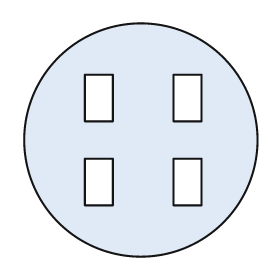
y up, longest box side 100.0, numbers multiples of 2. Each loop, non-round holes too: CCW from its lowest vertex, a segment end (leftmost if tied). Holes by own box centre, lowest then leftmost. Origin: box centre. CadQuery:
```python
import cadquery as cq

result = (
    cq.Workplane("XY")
    .moveTo(0.0, 0.0)
    .circle(50.0)
    .moveTo(-24.0, -28.0)
    .lineTo(-12.0, -28.0)
    .lineTo(-12.0, -8.0)
    .lineTo(-24.0, -8.0)
    .close()
    .moveTo(14.0, -28.0)
    .lineTo(26.0, -28.0)
    .lineTo(26.0, -8.0)
    .lineTo(14.0, -8.0)
    .close()
    .moveTo(-24.0, 8.0)
    .lineTo(-12.0, 8.0)
    .lineTo(-12.0, 28.0)
    .lineTo(-24.0, 28.0)
    .close()
    .moveTo(14.0, 8.0)
    .lineTo(26.0, 8.0)
    .lineTo(26.0, 28.0)
    .lineTo(14.0, 28.0)
    .close()
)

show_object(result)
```